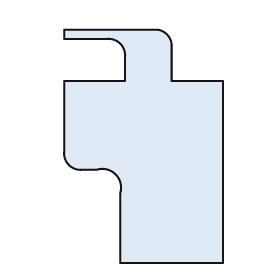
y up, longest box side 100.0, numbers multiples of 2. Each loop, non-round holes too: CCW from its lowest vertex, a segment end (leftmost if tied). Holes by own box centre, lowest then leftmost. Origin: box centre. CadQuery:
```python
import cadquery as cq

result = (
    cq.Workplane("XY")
    .moveTo(-10.0, -50.0)
    .lineTo(34.0, -50.0)
    .lineTo(34.0, 28.0)
    .lineTo(12.0, 28.0)
    .lineTo(12.0, 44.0)
    .threePointArc((10.0, 48.0), (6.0, 50.0))
    .lineTo(-34.0, 50.0)
    .lineTo(-34.0, 46.0)
    .lineTo(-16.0, 46.0)
    .threePointArc((-10.0, 44.0), (-8.0, 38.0))
    .lineTo(-8.0, 28.0)
    .lineTo(-34.0, 28.0)
    .lineTo(-34.0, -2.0)
    .threePointArc((-32.0, -8.0), (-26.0, -10.0))
    .lineTo(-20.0, -10.0)
    .threePointArc((-12.0, -12.0), (-10.0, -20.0))
    .close()
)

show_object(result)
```